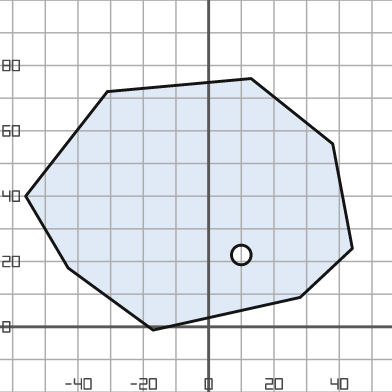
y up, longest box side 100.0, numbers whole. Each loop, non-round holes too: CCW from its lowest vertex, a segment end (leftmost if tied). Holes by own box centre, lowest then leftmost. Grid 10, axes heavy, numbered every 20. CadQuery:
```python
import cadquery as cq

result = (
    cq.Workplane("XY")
    .moveTo(-17.0, -1.0)
    .lineTo(28.0, 9.0)
    .lineTo(44.0, 24.0)
    .lineTo(38.0, 56.0)
    .lineTo(13.0, 76.0)
    .lineTo(-31.0, 72.0)
    .lineTo(-56.0, 40.0)
    .lineTo(-43.0, 18.0)
    .close()
    .moveTo(10.0, 22.0)
    .circle(3.0)
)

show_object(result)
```